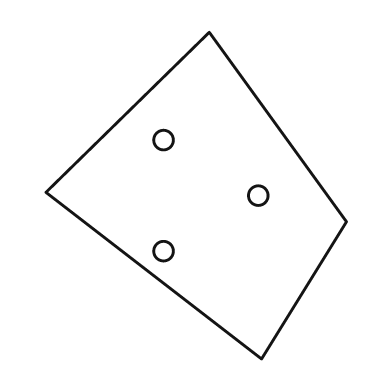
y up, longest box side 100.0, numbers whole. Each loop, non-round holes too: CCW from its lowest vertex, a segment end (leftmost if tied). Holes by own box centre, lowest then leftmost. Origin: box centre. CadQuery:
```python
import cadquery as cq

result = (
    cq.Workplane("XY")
    .moveTo(20.0, -50.0)
    .lineTo(46.0, -8.0)
    .lineTo(4.0, 50.0)
    .lineTo(-46.0, 1.0)
    .close()
    .moveTo(-10.0, -17.0)
    .circle(3.0)
    .moveTo(19.0, 0.0)
    .circle(3.0)
    .moveTo(-10.0, 17.0)
    .circle(3.0)
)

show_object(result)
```